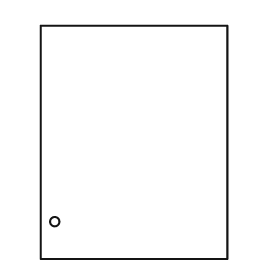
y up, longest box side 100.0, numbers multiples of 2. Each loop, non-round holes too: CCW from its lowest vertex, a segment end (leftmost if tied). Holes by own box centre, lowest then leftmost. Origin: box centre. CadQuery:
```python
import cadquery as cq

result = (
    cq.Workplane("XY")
    .moveTo(-40.0, -50.0)
    .lineTo(40.0, -50.0)
    .lineTo(40.0, 50.0)
    .lineTo(-40.0, 50.0)
    .close()
    .moveTo(-34.0, -34.0)
    .circle(2.0)
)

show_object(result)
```